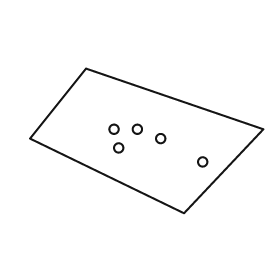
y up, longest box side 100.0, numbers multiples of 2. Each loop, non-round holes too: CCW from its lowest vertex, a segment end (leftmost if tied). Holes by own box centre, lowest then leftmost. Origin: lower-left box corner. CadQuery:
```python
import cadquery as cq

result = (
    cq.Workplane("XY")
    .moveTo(66.0, 0.0)
    .lineTo(100.0, 36.0)
    .lineTo(24.0, 62.0)
    .lineTo(0.0, 32.0)
    .close()
    .moveTo(74.0, 22.0)
    .circle(2.0)
    .moveTo(38.0, 28.0)
    .circle(2.0)
    .moveTo(56.0, 32.0)
    .circle(2.0)
    .moveTo(36.0, 36.0)
    .circle(2.0)
    .moveTo(46.0, 36.0)
    .circle(2.0)
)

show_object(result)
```